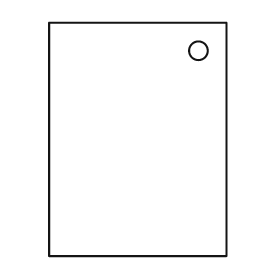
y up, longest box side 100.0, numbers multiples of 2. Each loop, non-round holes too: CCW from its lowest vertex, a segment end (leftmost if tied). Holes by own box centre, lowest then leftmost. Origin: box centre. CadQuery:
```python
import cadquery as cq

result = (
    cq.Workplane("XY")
    .moveTo(-38.0, -50.0)
    .lineTo(38.0, -50.0)
    .lineTo(38.0, 50.0)
    .lineTo(-38.0, 50.0)
    .close()
    .moveTo(26.0, 38.0)
    .circle(4.0)
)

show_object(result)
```